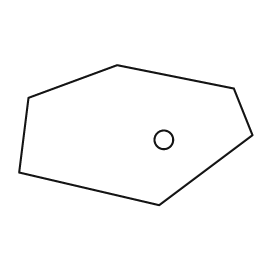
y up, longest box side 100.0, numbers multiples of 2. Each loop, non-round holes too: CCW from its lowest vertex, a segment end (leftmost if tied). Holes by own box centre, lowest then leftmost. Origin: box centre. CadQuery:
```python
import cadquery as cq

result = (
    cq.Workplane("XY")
    .moveTo(10.0, -30.0)
    .lineTo(50.0, 0.0)
    .lineTo(42.0, 20.0)
    .lineTo(-8.0, 30.0)
    .lineTo(-46.0, 16.0)
    .lineTo(-50.0, -16.0)
    .close()
    .moveTo(12.0, -2.0)
    .circle(4.0)
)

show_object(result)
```